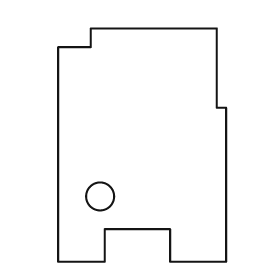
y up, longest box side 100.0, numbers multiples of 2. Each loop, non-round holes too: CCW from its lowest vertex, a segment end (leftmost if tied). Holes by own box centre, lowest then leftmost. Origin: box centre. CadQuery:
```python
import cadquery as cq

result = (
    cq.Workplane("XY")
    .moveTo(-36.0, -50.0)
    .lineTo(-16.0, -50.0)
    .lineTo(-16.0, -36.0)
    .lineTo(12.0, -36.0)
    .lineTo(12.0, -50.0)
    .lineTo(36.0, -50.0)
    .lineTo(36.0, 16.0)
    .lineTo(32.0, 16.0)
    .lineTo(32.0, 50.0)
    .lineTo(-22.0, 50.0)
    .lineTo(-22.0, 42.0)
    .lineTo(-36.0, 42.0)
    .close()
    .moveTo(-18.0, -22.0)
    .circle(6.0)
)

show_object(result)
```